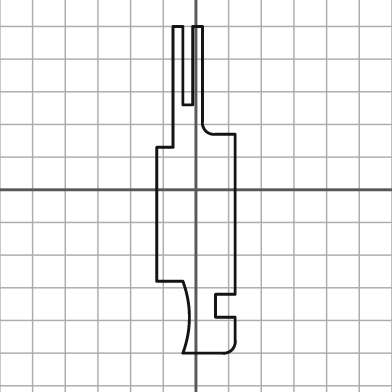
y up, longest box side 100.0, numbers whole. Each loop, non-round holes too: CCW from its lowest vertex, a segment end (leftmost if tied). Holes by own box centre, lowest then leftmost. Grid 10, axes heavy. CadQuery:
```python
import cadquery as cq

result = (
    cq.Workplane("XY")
    .moveTo(-4.0, -50.0)
    .lineTo(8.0, -50.0)
    .threePointArc((11.0, -49.0), (12.0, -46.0))
    .lineTo(12.0, -39.0)
    .lineTo(6.0, -39.0)
    .lineTo(6.0, -32.0)
    .lineTo(12.0, -32.0)
    .lineTo(12.0, 17.0)
    .lineTo(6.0, 17.0)
    .threePointArc((3.0, 18.0), (2.0, 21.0))
    .lineTo(2.0, 50.0)
    .lineTo(-1.0, 50.0)
    .lineTo(-1.0, 26.0)
    .lineTo(-4.0, 26.0)
    .lineTo(-4.0, 50.0)
    .lineTo(-7.0, 50.0)
    .lineTo(-7.0, 13.0)
    .lineTo(-12.0, 13.0)
    .lineTo(-12.0, -28.0)
    .lineTo(-4.0, -28.0)
    .threePointArc((-2.0, -39.0), (-4.0, -50.0))
    .close()
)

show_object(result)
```